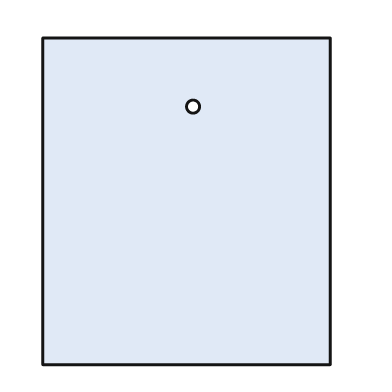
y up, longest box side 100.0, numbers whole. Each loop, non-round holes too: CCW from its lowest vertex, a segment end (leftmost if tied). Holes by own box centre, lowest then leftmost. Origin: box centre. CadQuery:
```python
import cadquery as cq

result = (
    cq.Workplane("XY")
    .moveTo(-44.0, -50.0)
    .lineTo(44.0, -50.0)
    .lineTo(44.0, 50.0)
    .lineTo(-44.0, 50.0)
    .close()
    .moveTo(2.0, 29.0)
    .circle(2.0)
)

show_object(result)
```